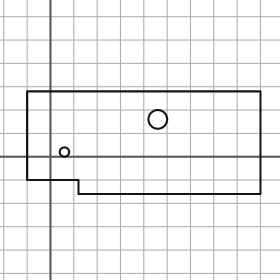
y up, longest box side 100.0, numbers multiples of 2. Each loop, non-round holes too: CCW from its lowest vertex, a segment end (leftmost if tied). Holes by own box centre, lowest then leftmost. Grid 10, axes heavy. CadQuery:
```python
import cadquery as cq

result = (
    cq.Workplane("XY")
    .moveTo(12.0, -16.0)
    .lineTo(90.0, -16.0)
    .lineTo(90.0, 28.0)
    .lineTo(-10.0, 28.0)
    .lineTo(-10.0, -10.0)
    .lineTo(12.0, -10.0)
    .close()
    .moveTo(6.0, 2.0)
    .circle(2.0)
    .moveTo(46.0, 16.0)
    .circle(4.0)
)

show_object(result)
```